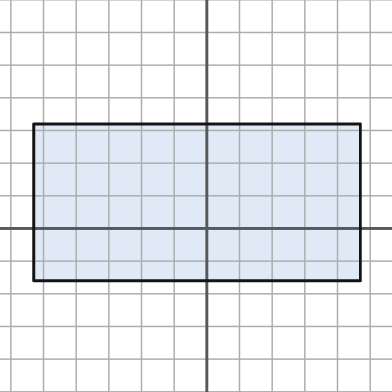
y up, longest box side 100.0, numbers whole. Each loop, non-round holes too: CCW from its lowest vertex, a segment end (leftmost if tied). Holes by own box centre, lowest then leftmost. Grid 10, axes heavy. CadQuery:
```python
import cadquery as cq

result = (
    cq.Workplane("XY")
    .moveTo(-53.0, -16.0)
    .lineTo(47.0, -16.0)
    .lineTo(47.0, 32.0)
    .lineTo(-53.0, 32.0)
    .close()
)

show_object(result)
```